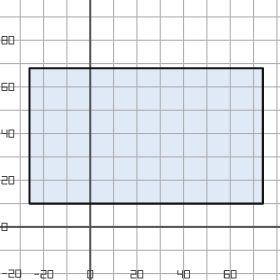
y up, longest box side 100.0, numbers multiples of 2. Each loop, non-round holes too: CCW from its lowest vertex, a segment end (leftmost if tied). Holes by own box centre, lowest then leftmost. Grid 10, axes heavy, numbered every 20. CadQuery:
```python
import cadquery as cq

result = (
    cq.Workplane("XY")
    .moveTo(-26.0, 10.0)
    .lineTo(74.0, 10.0)
    .lineTo(74.0, 68.0)
    .lineTo(-26.0, 68.0)
    .close()
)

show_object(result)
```